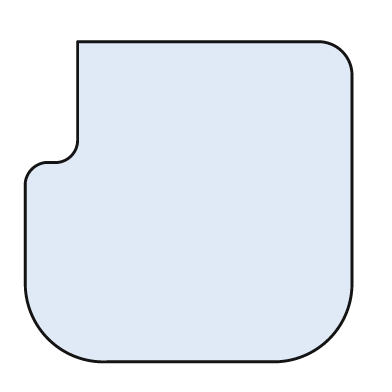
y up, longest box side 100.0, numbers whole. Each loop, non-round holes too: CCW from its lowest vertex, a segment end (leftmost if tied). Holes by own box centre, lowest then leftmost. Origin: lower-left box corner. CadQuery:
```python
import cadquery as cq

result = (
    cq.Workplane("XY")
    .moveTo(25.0, 0.0)
    .lineTo(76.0, 0.0)
    .threePointArc((93.0, 7.0), (100.0, 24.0))
    .lineTo(100.0, 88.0)
    .threePointArc((97.0, 95.0), (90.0, 98.0))
    .lineTo(16.0, 98.0)
    .lineTo(16.0, 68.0)
    .threePointArc((14.0, 63.0), (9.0, 61.0))
    .lineTo(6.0, 61.0)
    .threePointArc((2.0, 59.0), (0.0, 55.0))
    .lineTo(0.0, 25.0)
    .threePointArc((7.0, 7.0), (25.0, 0.0))
    .close()
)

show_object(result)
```